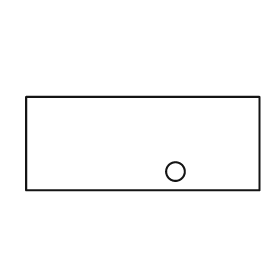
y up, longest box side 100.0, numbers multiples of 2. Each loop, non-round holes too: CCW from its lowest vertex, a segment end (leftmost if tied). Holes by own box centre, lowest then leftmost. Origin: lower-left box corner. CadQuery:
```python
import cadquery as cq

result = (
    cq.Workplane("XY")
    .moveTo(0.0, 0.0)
    .lineTo(100.0, 0.0)
    .lineTo(100.0, 40.0)
    .lineTo(0.0, 40.0)
    .close()
    .moveTo(64.0, 8.0)
    .circle(4.0)
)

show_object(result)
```